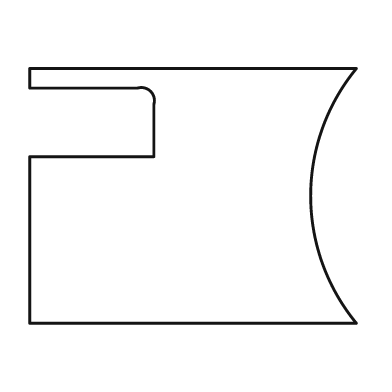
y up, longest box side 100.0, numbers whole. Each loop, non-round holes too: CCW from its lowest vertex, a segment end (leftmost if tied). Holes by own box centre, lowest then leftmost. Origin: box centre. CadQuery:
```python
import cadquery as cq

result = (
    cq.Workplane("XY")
    .moveTo(-50.0, -39.0)
    .lineTo(50.0, -39.0)
    .threePointArc((36.0, 0.0), (50.0, 39.0))
    .lineTo(-50.0, 39.0)
    .lineTo(-50.0, 33.0)
    .lineTo(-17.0, 33.0)
    .threePointArc((-13.0, 32.0), (-12.0, 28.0))
    .lineTo(-12.0, 12.0)
    .lineTo(-50.0, 12.0)
    .close()
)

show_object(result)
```